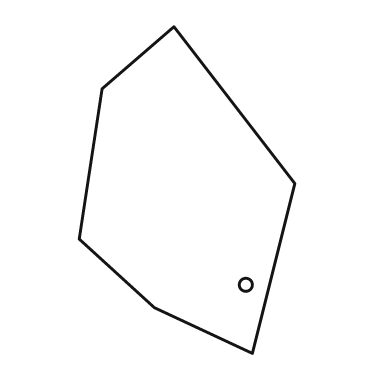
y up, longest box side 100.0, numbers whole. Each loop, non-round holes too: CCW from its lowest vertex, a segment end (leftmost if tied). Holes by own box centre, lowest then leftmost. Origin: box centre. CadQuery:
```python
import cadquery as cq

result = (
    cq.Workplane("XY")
    .moveTo(20.0, -50.0)
    .lineTo(33.0, 2.0)
    .lineTo(-4.0, 50.0)
    .lineTo(-26.0, 31.0)
    .lineTo(-33.0, -15.0)
    .lineTo(-10.0, -36.0)
    .close()
    .moveTo(18.0, -29.0)
    .circle(2.0)
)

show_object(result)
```